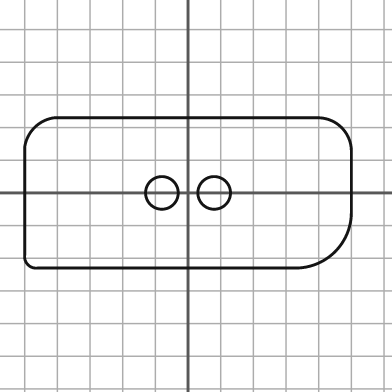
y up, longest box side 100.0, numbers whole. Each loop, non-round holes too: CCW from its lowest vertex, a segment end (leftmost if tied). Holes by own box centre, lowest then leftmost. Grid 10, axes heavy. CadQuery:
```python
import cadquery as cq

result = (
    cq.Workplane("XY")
    .moveTo(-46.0, -23.0)
    .lineTo(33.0, -23.0)
    .threePointArc((45.0, -18.0), (50.0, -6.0))
    .lineTo(50.0, 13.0)
    .threePointArc((47.0, 20.0), (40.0, 23.0))
    .lineTo(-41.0, 23.0)
    .threePointArc((-47.0, 20.0), (-50.0, 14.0))
    .lineTo(-50.0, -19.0)
    .threePointArc((-49.0, -22.0), (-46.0, -23.0))
    .close()
    .moveTo(-8.0, 0.0)
    .circle(5.0)
    .moveTo(8.0, 0.0)
    .circle(5.0)
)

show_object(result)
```